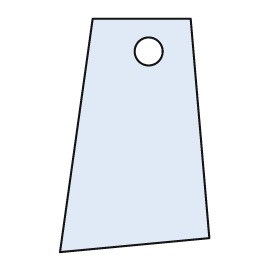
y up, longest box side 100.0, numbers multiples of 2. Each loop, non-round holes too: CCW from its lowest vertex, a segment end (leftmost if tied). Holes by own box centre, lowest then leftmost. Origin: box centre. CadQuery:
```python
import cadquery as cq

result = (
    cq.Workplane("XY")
    .moveTo(-32.0, -50.0)
    .lineTo(32.0, -44.0)
    .lineTo(24.0, 50.0)
    .lineTo(-18.0, 50.0)
    .close()
    .moveTo(6.0, 36.0)
    .circle(6.0)
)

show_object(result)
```